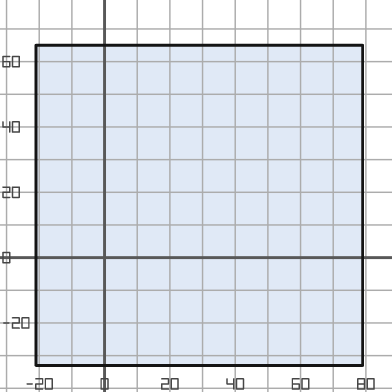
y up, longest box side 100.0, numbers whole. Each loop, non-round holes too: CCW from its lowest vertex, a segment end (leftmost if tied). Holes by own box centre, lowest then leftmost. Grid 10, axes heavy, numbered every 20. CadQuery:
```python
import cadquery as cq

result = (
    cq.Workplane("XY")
    .moveTo(-21.0, -33.0)
    .lineTo(79.0, -33.0)
    .lineTo(79.0, 65.0)
    .lineTo(-21.0, 65.0)
    .close()
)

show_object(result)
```